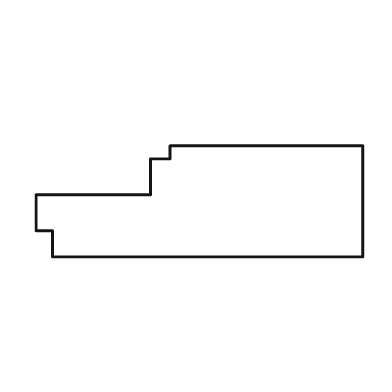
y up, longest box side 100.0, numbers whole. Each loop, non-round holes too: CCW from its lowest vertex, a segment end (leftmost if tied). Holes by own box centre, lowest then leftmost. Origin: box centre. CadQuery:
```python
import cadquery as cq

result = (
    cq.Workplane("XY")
    .moveTo(-45.0, -17.0)
    .lineTo(50.0, -17.0)
    .lineTo(50.0, 17.0)
    .lineTo(-9.0, 17.0)
    .lineTo(-9.0, 13.0)
    .lineTo(-15.0, 13.0)
    .lineTo(-15.0, 2.0)
    .lineTo(-50.0, 2.0)
    .lineTo(-50.0, -9.0)
    .lineTo(-45.0, -9.0)
    .close()
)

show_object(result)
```